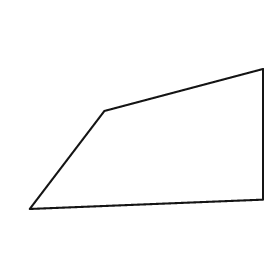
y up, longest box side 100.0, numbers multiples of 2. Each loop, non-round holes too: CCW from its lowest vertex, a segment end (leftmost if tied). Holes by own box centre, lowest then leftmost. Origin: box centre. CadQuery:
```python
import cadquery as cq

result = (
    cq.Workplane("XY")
    .moveTo(-50.0, -30.0)
    .lineTo(50.0, -26.0)
    .lineTo(50.0, 30.0)
    .lineTo(-18.0, 12.0)
    .close()
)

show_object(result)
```